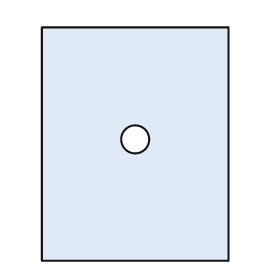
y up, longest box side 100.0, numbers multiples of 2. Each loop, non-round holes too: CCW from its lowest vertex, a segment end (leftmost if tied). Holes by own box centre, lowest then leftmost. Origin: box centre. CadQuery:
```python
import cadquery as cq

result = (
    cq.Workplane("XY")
    .moveTo(-40.0, -50.0)
    .lineTo(40.0, -50.0)
    .lineTo(40.0, 50.0)
    .lineTo(-40.0, 50.0)
    .close()
    .moveTo(0.0, 2.0)
    .circle(6.0)
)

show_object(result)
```